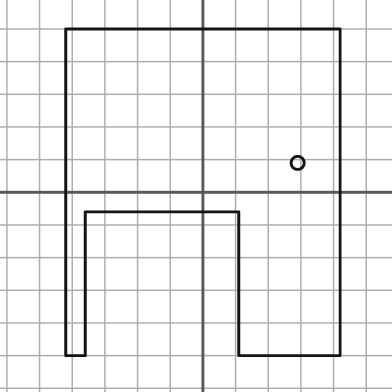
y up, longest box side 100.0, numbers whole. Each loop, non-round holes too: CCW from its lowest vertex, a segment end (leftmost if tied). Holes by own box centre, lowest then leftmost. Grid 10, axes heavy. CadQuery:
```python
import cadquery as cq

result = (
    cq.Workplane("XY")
    .moveTo(-42.0, -50.0)
    .lineTo(-36.0, -50.0)
    .lineTo(-36.0, -6.0)
    .lineTo(11.0, -6.0)
    .lineTo(11.0, -50.0)
    .lineTo(42.0, -50.0)
    .lineTo(42.0, 50.0)
    .lineTo(-42.0, 50.0)
    .close()
    .moveTo(29.0, 9.0)
    .circle(2.0)
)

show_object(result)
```